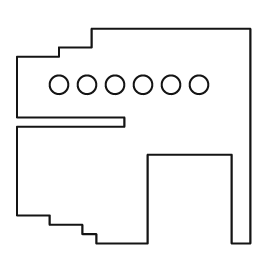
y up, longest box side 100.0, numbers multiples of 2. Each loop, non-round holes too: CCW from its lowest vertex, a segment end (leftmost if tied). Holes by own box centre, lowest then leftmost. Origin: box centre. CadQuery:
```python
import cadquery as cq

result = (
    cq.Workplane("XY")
    .moveTo(-16.0, -46.0)
    .lineTo(6.0, -46.0)
    .lineTo(6.0, -8.0)
    .lineTo(42.0, -8.0)
    .lineTo(42.0, -46.0)
    .lineTo(50.0, -46.0)
    .lineTo(50.0, 46.0)
    .lineTo(-18.0, 46.0)
    .lineTo(-18.0, 38.0)
    .lineTo(-32.0, 38.0)
    .lineTo(-32.0, 34.0)
    .lineTo(-50.0, 34.0)
    .lineTo(-50.0, 8.0)
    .lineTo(-4.0, 8.0)
    .lineTo(-4.0, 4.0)
    .lineTo(-50.0, 4.0)
    .lineTo(-50.0, -34.0)
    .lineTo(-36.0, -34.0)
    .lineTo(-36.0, -38.0)
    .lineTo(-22.0, -38.0)
    .lineTo(-22.0, -42.0)
    .lineTo(-16.0, -42.0)
    .close()
    .moveTo(-32.0, 22.0)
    .circle(4.0)
    .moveTo(-20.0, 22.0)
    .circle(4.0)
    .moveTo(-8.0, 22.0)
    .circle(4.0)
    .moveTo(4.0, 22.0)
    .circle(4.0)
    .moveTo(16.0, 22.0)
    .circle(4.0)
    .moveTo(28.0, 22.0)
    .circle(4.0)
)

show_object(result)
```